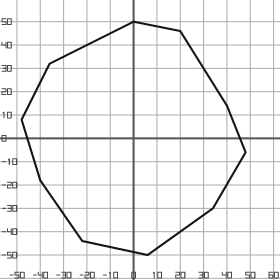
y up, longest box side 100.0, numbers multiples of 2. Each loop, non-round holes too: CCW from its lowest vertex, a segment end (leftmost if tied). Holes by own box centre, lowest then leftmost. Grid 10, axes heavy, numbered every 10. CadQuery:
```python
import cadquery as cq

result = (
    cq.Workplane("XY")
    .moveTo(6.0, -50.0)
    .lineTo(34.0, -30.0)
    .lineTo(48.0, -6.0)
    .lineTo(40.0, 14.0)
    .lineTo(20.0, 46.0)
    .lineTo(0.0, 50.0)
    .lineTo(-36.0, 32.0)
    .lineTo(-48.0, 8.0)
    .lineTo(-40.0, -18.0)
    .lineTo(-22.0, -44.0)
    .close()
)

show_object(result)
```